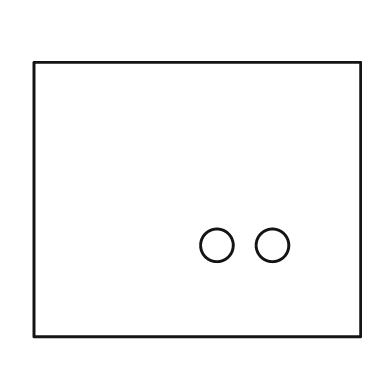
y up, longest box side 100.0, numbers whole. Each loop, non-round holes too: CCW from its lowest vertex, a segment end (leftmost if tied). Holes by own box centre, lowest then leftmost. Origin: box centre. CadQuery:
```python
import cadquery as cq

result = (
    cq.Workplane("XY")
    .moveTo(-50.0, -42.0)
    .lineTo(50.0, -42.0)
    .lineTo(50.0, 42.0)
    .lineTo(-50.0, 42.0)
    .close()
    .moveTo(6.0, -14.0)
    .circle(5.0)
    .moveTo(23.0, -14.0)
    .circle(5.0)
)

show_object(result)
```